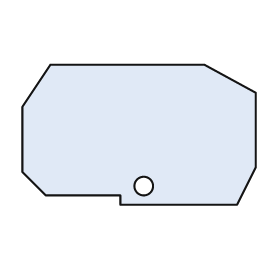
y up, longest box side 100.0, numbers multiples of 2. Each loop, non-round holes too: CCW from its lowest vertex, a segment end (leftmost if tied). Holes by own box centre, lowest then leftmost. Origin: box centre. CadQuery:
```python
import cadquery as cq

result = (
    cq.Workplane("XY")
    .moveTo(-8.0, -30.0)
    .lineTo(42.0, -30.0)
    .lineTo(50.0, -14.0)
    .lineTo(50.0, 18.0)
    .lineTo(28.0, 30.0)
    .lineTo(-38.0, 30.0)
    .lineTo(-50.0, 12.0)
    .lineTo(-50.0, -16.0)
    .lineTo(-40.0, -26.0)
    .lineTo(-8.0, -26.0)
    .close()
    .moveTo(2.0, -22.0)
    .circle(4.0)
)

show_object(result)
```